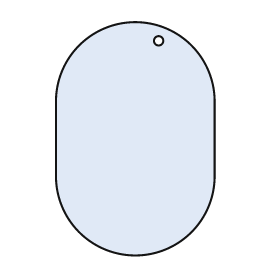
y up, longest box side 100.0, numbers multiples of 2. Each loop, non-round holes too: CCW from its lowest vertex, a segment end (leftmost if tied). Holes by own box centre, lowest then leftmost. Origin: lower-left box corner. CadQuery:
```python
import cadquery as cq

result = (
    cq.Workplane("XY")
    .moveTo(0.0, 34.0)
    .threePointArc((34.0, 0.0), (68.0, 34.0))
    .lineTo(68.0, 66.0)
    .threePointArc((34.0, 100.0), (0.0, 66.0))
    .close()
    .moveTo(44.0, 92.0)
    .circle(2.0)
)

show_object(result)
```